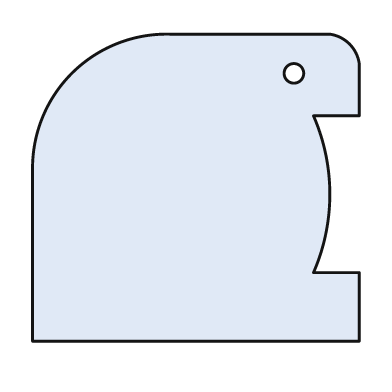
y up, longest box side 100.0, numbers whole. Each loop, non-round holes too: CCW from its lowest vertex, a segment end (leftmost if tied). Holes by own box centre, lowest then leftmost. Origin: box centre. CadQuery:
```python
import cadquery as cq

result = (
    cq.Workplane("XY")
    .moveTo(-50.0, -47.0)
    .lineTo(50.0, -47.0)
    .lineTo(50.0, -26.0)
    .lineTo(36.0, -26.0)
    .threePointArc((41.0, -2.0), (36.0, 22.0))
    .lineTo(50.0, 22.0)
    .lineTo(50.0, 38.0)
    .threePointArc((47.0, 44.0), (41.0, 47.0))
    .lineTo(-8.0, 47.0)
    .threePointArc((-38.0, 35.0), (-50.0, 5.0))
    .close()
    .moveTo(30.0, 35.0)
    .circle(3.0)
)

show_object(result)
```